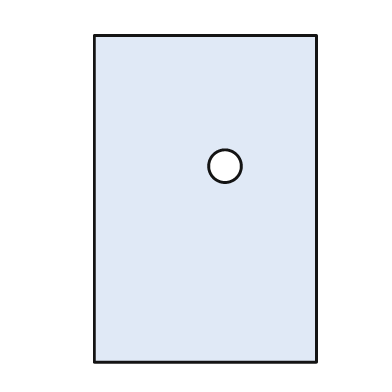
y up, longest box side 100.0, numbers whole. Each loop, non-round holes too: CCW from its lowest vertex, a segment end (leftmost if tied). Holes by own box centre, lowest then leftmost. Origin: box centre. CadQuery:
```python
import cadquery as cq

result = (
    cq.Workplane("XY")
    .moveTo(-34.0, -50.0)
    .lineTo(34.0, -50.0)
    .lineTo(34.0, 50.0)
    .lineTo(-34.0, 50.0)
    .close()
    .moveTo(6.0, 10.0)
    .circle(5.0)
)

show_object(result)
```